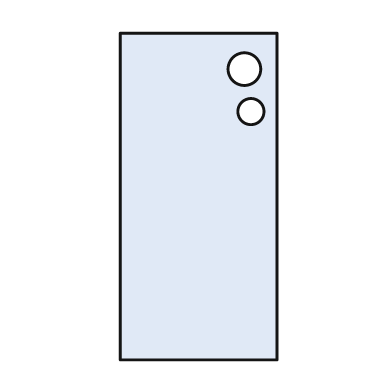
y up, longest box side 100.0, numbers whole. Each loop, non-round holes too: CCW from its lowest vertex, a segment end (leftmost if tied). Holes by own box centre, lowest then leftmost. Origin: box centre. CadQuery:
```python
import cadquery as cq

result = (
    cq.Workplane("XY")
    .moveTo(-24.0, -50.0)
    .lineTo(24.0, -50.0)
    .lineTo(24.0, 50.0)
    .lineTo(-24.0, 50.0)
    .close()
    .moveTo(16.0, 26.0)
    .circle(4.0)
    .moveTo(14.0, 39.0)
    .circle(5.0)
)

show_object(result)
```